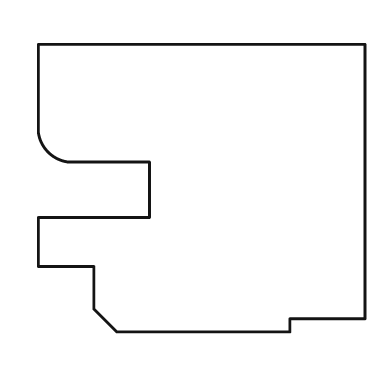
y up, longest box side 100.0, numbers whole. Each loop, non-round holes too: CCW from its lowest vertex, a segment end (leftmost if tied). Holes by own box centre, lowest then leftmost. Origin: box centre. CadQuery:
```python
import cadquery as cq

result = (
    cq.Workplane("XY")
    .moveTo(-26.0, -44.0)
    .lineTo(27.0, -44.0)
    .lineTo(27.0, -40.0)
    .lineTo(50.0, -40.0)
    .lineTo(50.0, 44.0)
    .lineTo(-50.0, 44.0)
    .lineTo(-50.0, 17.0)
    .threePointArc((-47.0, 11.0), (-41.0, 8.0))
    .lineTo(-16.0, 8.0)
    .lineTo(-16.0, -9.0)
    .lineTo(-50.0, -9.0)
    .lineTo(-50.0, -24.0)
    .lineTo(-33.0, -24.0)
    .lineTo(-33.0, -37.0)
    .close()
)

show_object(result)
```